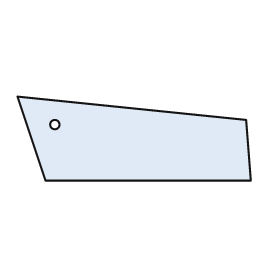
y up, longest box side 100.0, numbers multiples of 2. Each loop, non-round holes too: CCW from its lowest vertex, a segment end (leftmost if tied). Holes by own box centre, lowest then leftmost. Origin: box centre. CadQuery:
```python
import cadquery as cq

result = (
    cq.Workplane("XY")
    .moveTo(-38.0, -18.0)
    .lineTo(50.0, -18.0)
    .lineTo(48.0, 8.0)
    .lineTo(-50.0, 18.0)
    .close()
    .moveTo(-34.0, 6.0)
    .circle(2.0)
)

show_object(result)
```